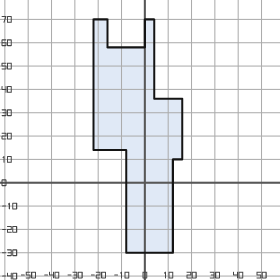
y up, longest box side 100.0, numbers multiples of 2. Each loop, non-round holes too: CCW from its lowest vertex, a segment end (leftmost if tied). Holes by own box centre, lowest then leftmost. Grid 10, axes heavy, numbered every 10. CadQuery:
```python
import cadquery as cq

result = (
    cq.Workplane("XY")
    .moveTo(-8.0, -30.0)
    .lineTo(12.0, -30.0)
    .lineTo(12.0, 10.0)
    .lineTo(16.0, 10.0)
    .lineTo(16.0, 36.0)
    .lineTo(4.0, 36.0)
    .lineTo(4.0, 70.0)
    .lineTo(0.0, 70.0)
    .lineTo(0.0, 58.0)
    .lineTo(-16.0, 58.0)
    .lineTo(-16.0, 70.0)
    .lineTo(-22.0, 70.0)
    .lineTo(-22.0, 14.0)
    .lineTo(-8.0, 14.0)
    .close()
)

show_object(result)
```